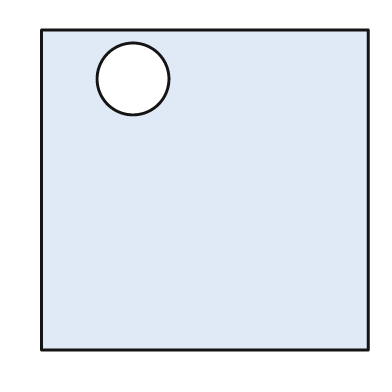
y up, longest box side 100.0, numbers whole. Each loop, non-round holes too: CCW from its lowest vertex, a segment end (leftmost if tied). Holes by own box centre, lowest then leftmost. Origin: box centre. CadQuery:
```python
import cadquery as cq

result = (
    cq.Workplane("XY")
    .moveTo(-50.0, -49.0)
    .lineTo(50.0, -49.0)
    .lineTo(50.0, 49.0)
    .lineTo(-50.0, 49.0)
    .close()
    .moveTo(-22.0, 34.0)
    .circle(11.0)
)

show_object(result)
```